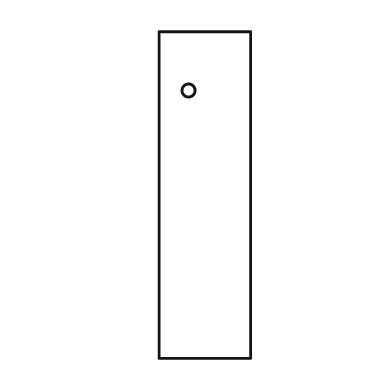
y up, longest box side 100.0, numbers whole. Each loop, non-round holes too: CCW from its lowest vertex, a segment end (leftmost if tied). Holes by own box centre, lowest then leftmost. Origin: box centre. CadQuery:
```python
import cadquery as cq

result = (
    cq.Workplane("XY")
    .moveTo(-14.0, -50.0)
    .lineTo(14.0, -50.0)
    .lineTo(14.0, 50.0)
    .lineTo(-14.0, 50.0)
    .close()
    .moveTo(-5.0, 32.0)
    .circle(2.0)
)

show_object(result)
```